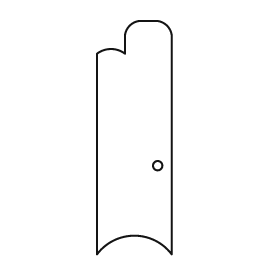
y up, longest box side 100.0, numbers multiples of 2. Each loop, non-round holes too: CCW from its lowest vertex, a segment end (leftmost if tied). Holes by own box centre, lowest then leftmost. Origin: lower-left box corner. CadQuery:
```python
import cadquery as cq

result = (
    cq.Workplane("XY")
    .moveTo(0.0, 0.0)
    .threePointArc((16.0, 8.0), (32.0, 0.0))
    .lineTo(32.0, 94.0)
    .threePointArc((30.0, 98.0), (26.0, 100.0))
    .lineTo(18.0, 100.0)
    .threePointArc((14.0, 98.0), (12.0, 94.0))
    .lineTo(12.0, 86.0)
    .threePointArc((6.0, 88.0), (0.0, 86.0))
    .close()
    .moveTo(26.0, 38.0)
    .circle(2.0)
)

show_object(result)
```